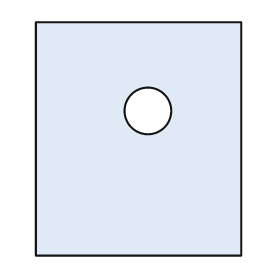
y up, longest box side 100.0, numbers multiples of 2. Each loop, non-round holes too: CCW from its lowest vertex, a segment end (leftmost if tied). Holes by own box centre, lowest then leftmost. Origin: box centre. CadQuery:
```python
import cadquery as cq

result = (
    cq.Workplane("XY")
    .moveTo(-44.0, -50.0)
    .lineTo(44.0, -50.0)
    .lineTo(44.0, 50.0)
    .lineTo(-44.0, 50.0)
    .close()
    .moveTo(4.0, 12.0)
    .circle(10.0)
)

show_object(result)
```